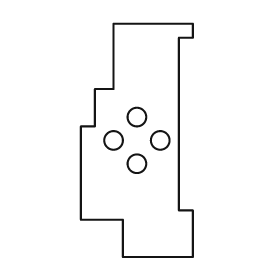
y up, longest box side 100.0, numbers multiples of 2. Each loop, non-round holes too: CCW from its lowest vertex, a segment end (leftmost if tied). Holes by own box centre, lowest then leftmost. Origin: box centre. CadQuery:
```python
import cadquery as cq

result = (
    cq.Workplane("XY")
    .moveTo(-6.0, -50.0)
    .lineTo(24.0, -50.0)
    .lineTo(24.0, -30.0)
    .lineTo(18.0, -30.0)
    .lineTo(18.0, 44.0)
    .lineTo(24.0, 44.0)
    .lineTo(24.0, 50.0)
    .lineTo(-10.0, 50.0)
    .lineTo(-10.0, 22.0)
    .lineTo(-18.0, 22.0)
    .lineTo(-18.0, 6.0)
    .lineTo(-24.0, 6.0)
    .lineTo(-24.0, -34.0)
    .lineTo(-6.0, -34.0)
    .close()
    .moveTo(0.0, -10.0)
    .circle(4.0)
    .moveTo(-10.0, 0.0)
    .circle(4.0)
    .moveTo(10.0, 0.0)
    .circle(4.0)
    .moveTo(0.0, 10.0)
    .circle(4.0)
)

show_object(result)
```